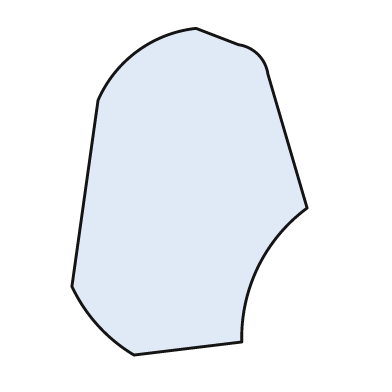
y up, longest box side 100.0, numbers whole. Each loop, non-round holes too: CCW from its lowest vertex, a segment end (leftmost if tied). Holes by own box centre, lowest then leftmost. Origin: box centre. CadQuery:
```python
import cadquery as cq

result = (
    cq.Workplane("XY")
    .moveTo(-17.0, -50.0)
    .lineTo(16.0, -46.0)
    .threePointArc((21.0, -23.0), (36.0, -5.0))
    .lineTo(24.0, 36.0)
    .threePointArc((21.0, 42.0), (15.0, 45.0))
    .lineTo(2.0, 50.0)
    .threePointArc((-16.0, 43.0), (-28.0, 28.0))
    .lineTo(-36.0, -29.0)
    .threePointArc((-28.0, -41.0), (-17.0, -50.0))
    .close()
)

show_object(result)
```